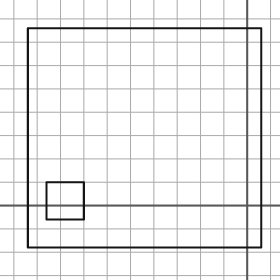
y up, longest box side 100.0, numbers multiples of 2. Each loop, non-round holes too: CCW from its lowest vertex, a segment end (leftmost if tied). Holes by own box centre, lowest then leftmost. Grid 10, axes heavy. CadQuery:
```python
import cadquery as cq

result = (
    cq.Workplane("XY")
    .moveTo(-94.0, -18.0)
    .lineTo(6.0, -18.0)
    .lineTo(6.0, 76.0)
    .lineTo(-94.0, 76.0)
    .close()
    .moveTo(-86.0, -6.0)
    .lineTo(-70.0, -6.0)
    .lineTo(-70.0, 10.0)
    .lineTo(-86.0, 10.0)
    .close()
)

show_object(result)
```